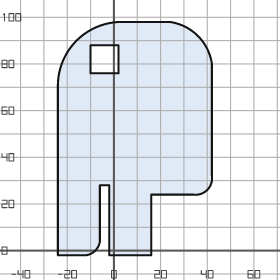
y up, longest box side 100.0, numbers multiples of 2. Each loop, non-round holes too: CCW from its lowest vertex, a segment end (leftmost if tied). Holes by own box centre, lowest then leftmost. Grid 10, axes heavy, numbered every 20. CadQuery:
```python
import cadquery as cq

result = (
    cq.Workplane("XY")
    .moveTo(-24.0, -2.0)
    .lineTo(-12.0, -2.0)
    .threePointArc((-8.0, 0.0), (-6.0, 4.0))
    .lineTo(-6.0, 28.0)
    .lineTo(-2.0, 28.0)
    .lineTo(-2.0, -2.0)
    .lineTo(16.0, -2.0)
    .lineTo(16.0, 24.0)
    .lineTo(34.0, 24.0)
    .threePointArc((40.0, 26.0), (42.0, 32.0))
    .lineTo(42.0, 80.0)
    .threePointArc((36.0, 92.0), (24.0, 98.0))
    .lineTo(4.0, 98.0)
    .threePointArc((-16.0, 90.0), (-24.0, 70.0))
    .close()
    .moveTo(-10.0, 76.0)
    .lineTo(2.0, 76.0)
    .lineTo(2.0, 88.0)
    .lineTo(-10.0, 88.0)
    .close()
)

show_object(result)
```